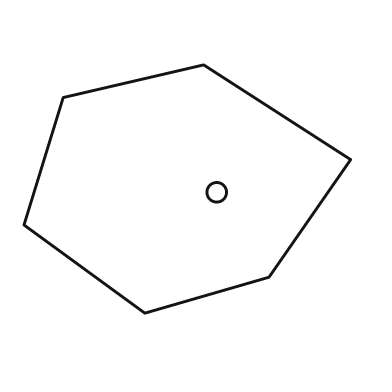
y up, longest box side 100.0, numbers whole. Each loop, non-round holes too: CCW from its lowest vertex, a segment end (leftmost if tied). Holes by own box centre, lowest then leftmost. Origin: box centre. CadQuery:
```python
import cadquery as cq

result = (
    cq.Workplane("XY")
    .moveTo(-13.0, -38.0)
    .lineTo(25.0, -27.0)
    .lineTo(50.0, 9.0)
    .lineTo(5.0, 38.0)
    .lineTo(-38.0, 28.0)
    .lineTo(-50.0, -11.0)
    .close()
    .moveTo(9.0, -1.0)
    .circle(3.0)
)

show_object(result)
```